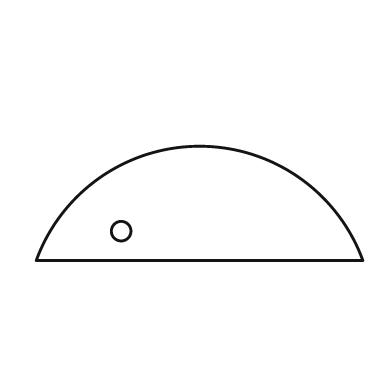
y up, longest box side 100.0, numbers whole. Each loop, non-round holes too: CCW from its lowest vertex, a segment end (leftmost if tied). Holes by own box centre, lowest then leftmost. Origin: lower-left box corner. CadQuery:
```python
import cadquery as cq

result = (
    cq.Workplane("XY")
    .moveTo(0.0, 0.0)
    .lineTo(100.0, 0.0)
    .threePointArc((50.0, 35.0), (0.0, 0.0))
    .close()
    .moveTo(26.0, 9.0)
    .circle(3.0)
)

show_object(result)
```